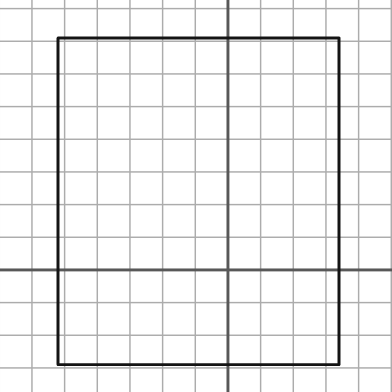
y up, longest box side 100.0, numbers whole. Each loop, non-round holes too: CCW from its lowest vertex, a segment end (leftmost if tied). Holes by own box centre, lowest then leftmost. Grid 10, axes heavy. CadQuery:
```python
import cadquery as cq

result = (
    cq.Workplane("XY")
    .moveTo(-52.0, -29.0)
    .lineTo(34.0, -29.0)
    .lineTo(34.0, 71.0)
    .lineTo(-52.0, 71.0)
    .close()
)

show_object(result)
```